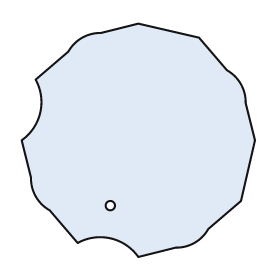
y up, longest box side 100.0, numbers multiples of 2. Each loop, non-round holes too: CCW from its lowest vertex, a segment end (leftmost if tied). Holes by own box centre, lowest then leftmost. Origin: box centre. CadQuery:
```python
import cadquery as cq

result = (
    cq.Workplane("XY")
    .moveTo(0.0, -50.0)
    .lineTo(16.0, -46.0)
    .threePointArc((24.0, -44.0), (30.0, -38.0))
    .lineTo(44.0, -26.0)
    .lineTo(50.0, 0.0)
    .lineTo(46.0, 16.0)
    .threePointArc((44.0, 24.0), (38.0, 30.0))
    .lineTo(26.0, 44.0)
    .lineTo(0.0, 50.0)
    .lineTo(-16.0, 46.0)
    .threePointArc((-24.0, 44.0), (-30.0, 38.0))
    .lineTo(-44.0, 26.0)
    .threePointArc((-42.0, 12.0), (-50.0, 0.0))
    .lineTo(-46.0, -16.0)
    .threePointArc((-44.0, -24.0), (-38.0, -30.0))
    .lineTo(-26.0, -44.0)
    .threePointArc((-12.0, -42.0), (0.0, -50.0))
    .close()
    .moveTo(-12.0, -28.0)
    .circle(2.0)
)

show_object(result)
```